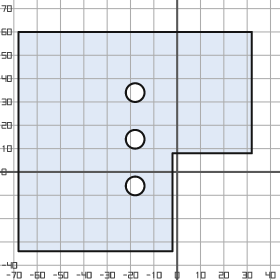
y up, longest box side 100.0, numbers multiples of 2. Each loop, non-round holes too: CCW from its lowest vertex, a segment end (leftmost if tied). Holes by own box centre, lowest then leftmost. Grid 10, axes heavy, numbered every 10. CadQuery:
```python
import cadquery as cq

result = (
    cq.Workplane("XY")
    .moveTo(-68.0, -34.0)
    .lineTo(-2.0, -34.0)
    .lineTo(-2.0, 8.0)
    .lineTo(32.0, 8.0)
    .lineTo(32.0, 60.0)
    .lineTo(-68.0, 60.0)
    .close()
    .moveTo(-18.0, -6.0)
    .circle(4.0)
    .moveTo(-18.0, 14.0)
    .circle(4.0)
    .moveTo(-18.0, 34.0)
    .circle(4.0)
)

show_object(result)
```